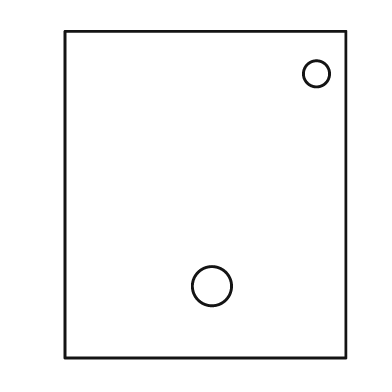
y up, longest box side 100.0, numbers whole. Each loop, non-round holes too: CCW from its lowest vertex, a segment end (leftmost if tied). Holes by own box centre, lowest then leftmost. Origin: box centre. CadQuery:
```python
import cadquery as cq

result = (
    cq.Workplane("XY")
    .moveTo(-43.0, -50.0)
    .lineTo(43.0, -50.0)
    .lineTo(43.0, 50.0)
    .lineTo(-43.0, 50.0)
    .close()
    .moveTo(2.0, -28.0)
    .circle(6.0)
    .moveTo(34.0, 37.0)
    .circle(4.0)
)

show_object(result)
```